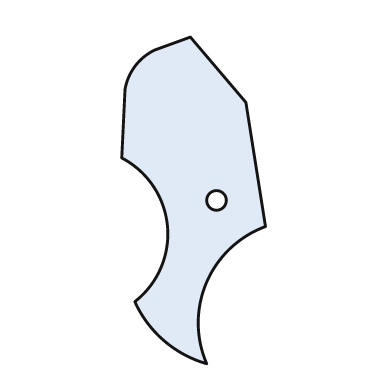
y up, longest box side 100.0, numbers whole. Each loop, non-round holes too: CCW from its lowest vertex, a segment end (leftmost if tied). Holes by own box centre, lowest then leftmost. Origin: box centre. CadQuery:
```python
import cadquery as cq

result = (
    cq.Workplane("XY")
    .moveTo(4.0, -50.0)
    .threePointArc((4.0, -25.0), (22.0, -8.0))
    .lineTo(16.0, 30.0)
    .lineTo(-1.0, 50.0)
    .lineTo(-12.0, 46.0)
    .threePointArc((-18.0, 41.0), (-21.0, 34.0))
    .lineTo(-22.0, 13.0)
    .threePointArc((-8.0, -8.0), (-18.0, -31.0))
    .threePointArc((-9.0, -43.0), (4.0, -50.0))
    .close()
    .moveTo(7.0, 0.0)
    .circle(3.0)
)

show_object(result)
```